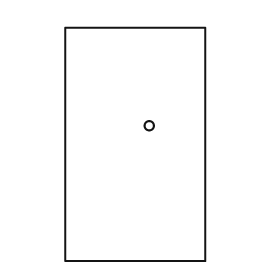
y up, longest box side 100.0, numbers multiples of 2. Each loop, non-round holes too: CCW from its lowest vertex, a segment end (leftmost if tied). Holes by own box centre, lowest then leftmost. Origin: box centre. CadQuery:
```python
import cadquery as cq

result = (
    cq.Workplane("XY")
    .moveTo(-30.0, -50.0)
    .lineTo(30.0, -50.0)
    .lineTo(30.0, 50.0)
    .lineTo(-30.0, 50.0)
    .close()
    .moveTo(6.0, 8.0)
    .circle(2.0)
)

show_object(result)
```